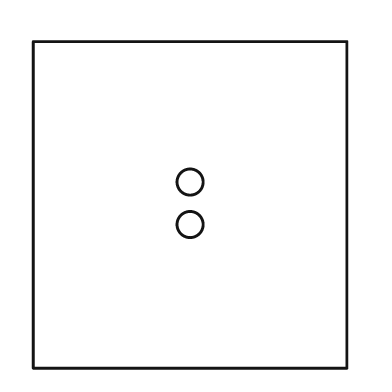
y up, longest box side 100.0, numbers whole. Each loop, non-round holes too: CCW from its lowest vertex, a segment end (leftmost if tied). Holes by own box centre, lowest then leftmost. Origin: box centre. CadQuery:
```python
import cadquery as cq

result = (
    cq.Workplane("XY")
    .moveTo(-48.0, -50.0)
    .lineTo(48.0, -50.0)
    .lineTo(48.0, 50.0)
    .lineTo(-48.0, 50.0)
    .close()
    .moveTo(0.0, -6.0)
    .circle(4.0)
    .moveTo(0.0, 7.0)
    .circle(4.0)
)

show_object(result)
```